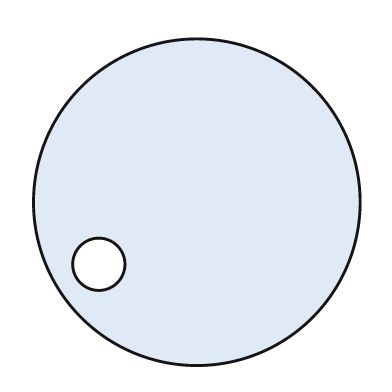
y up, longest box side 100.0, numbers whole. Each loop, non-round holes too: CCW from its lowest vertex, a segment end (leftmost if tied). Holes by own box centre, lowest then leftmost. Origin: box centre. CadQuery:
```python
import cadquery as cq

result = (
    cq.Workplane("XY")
    .moveTo(0.0, 0.0)
    .circle(50.0)
    .moveTo(-30.0, -19.0)
    .circle(8.0)
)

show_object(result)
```